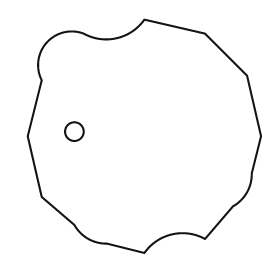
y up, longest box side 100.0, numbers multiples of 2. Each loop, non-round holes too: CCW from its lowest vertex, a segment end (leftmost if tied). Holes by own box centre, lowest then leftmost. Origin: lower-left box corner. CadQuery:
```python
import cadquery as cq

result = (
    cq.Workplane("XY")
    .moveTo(50.0, 0.0)
    .threePointArc((62.0, 8.0), (76.0, 6.0))
    .lineTo(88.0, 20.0)
    .threePointArc((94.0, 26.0), (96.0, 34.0))
    .lineTo(100.0, 50.0)
    .lineTo(94.0, 76.0)
    .lineTo(76.0, 94.0)
    .lineTo(50.0, 100.0)
    .threePointArc((38.0, 92.0), (24.0, 94.0))
    .threePointArc((8.0, 90.0), (6.0, 74.0))
    .lineTo(0.0, 50.0)
    .lineTo(6.0, 24.0)
    .lineTo(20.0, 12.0)
    .threePointArc((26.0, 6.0), (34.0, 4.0))
    .close()
    .moveTo(20.0, 52.0)
    .circle(4.0)
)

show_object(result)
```